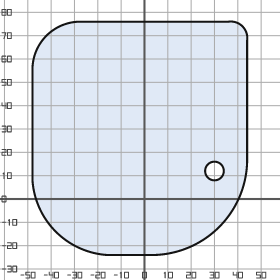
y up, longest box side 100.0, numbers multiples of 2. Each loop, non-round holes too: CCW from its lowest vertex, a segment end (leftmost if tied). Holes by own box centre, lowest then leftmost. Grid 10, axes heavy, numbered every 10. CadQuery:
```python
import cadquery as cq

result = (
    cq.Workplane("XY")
    .moveTo(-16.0, -24.0)
    .lineTo(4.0, -24.0)
    .threePointArc((32.0, -12.0), (44.0, 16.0))
    .lineTo(44.0, 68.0)
    .threePointArc((42.0, 74.0), (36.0, 76.0))
    .lineTo(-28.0, 76.0)
    .threePointArc((-42.0, 70.0), (-48.0, 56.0))
    .lineTo(-48.0, 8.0)
    .threePointArc((-38.0, -14.0), (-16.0, -24.0))
    .close()
    .moveTo(30.0, 12.0)
    .circle(4.0)
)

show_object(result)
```